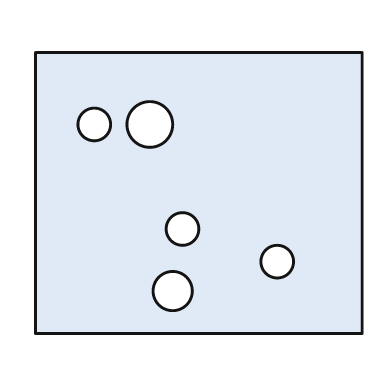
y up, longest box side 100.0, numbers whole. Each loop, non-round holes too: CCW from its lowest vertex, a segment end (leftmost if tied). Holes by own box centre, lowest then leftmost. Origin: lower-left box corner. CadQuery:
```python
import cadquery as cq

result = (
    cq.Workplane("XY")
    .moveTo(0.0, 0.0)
    .lineTo(100.0, 0.0)
    .lineTo(100.0, 86.0)
    .lineTo(0.0, 86.0)
    .close()
    .moveTo(42.0, 13.0)
    .circle(6.0)
    .moveTo(74.0, 22.0)
    .circle(5.0)
    .moveTo(45.0, 32.0)
    .circle(5.0)
    .moveTo(18.0, 64.0)
    .circle(5.0)
    .moveTo(35.0, 64.0)
    .circle(7.0)
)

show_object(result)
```